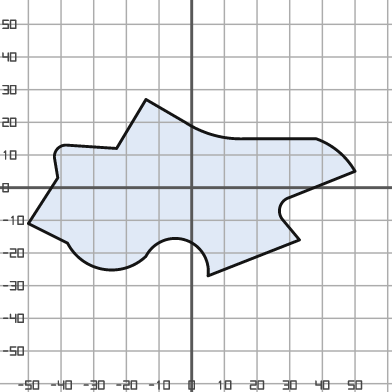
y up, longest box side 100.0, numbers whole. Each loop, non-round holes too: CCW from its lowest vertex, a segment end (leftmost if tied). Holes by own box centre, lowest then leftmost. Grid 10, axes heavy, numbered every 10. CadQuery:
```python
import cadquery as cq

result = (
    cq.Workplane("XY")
    .moveTo(5.0, -27.0)
    .lineTo(33.0, -16.0)
    .lineTo(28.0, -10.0)
    .threePointArc((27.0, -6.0), (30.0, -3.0))
    .lineTo(50.0, 5.0)
    .threePointArc((45.0, 11.0), (38.0, 15.0))
    .lineTo(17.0, 15.0)
    .threePointArc((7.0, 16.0), (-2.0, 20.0))
    .lineTo(-14.0, 27.0)
    .lineTo(-23.0, 12.0)
    .lineTo(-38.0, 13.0)
    .threePointArc((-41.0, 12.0), (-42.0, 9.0))
    .lineTo(-41.0, 3.0)
    .lineTo(-50.0, -11.0)
    .lineTo(-38.0, -17.0)
    .threePointArc((-27.0, -25.0), (-14.0, -21.0))
    .threePointArc((-2.0, -16.0), (5.0, -27.0))
    .close()
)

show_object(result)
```